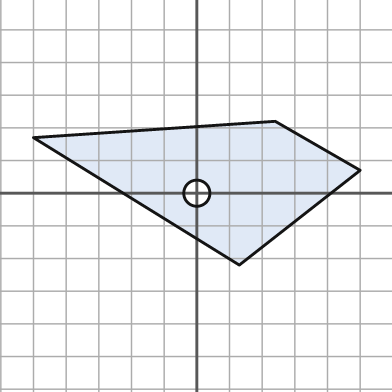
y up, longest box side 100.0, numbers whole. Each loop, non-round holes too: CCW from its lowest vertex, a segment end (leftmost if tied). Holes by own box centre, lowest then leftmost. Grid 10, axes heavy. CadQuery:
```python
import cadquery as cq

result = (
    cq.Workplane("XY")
    .moveTo(13.0, -22.0)
    .lineTo(50.0, 7.0)
    .lineTo(24.0, 22.0)
    .lineTo(-50.0, 17.0)
    .close()
    .moveTo(0.0, 0.0)
    .circle(4.0)
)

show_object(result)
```